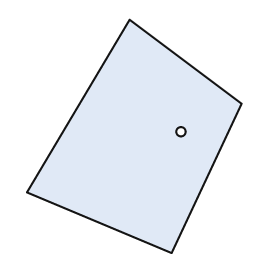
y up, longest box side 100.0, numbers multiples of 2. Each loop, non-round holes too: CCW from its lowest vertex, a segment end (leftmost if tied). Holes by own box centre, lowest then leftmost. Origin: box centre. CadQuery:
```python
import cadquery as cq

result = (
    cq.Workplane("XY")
    .moveTo(16.0, -50.0)
    .lineTo(46.0, 14.0)
    .lineTo(-2.0, 50.0)
    .lineTo(-46.0, -24.0)
    .close()
    .moveTo(20.0, 2.0)
    .circle(2.0)
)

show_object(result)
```